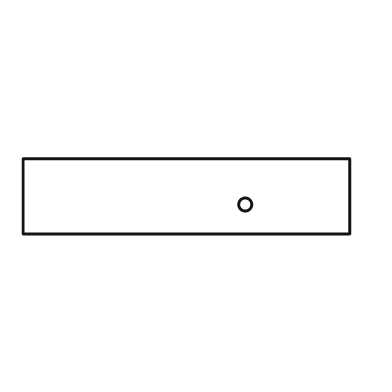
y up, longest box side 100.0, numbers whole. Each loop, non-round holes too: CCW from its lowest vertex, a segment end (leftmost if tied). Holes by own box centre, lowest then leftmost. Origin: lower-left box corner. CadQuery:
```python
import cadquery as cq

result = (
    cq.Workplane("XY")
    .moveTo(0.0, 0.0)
    .lineTo(100.0, 0.0)
    .lineTo(100.0, 23.0)
    .lineTo(0.0, 23.0)
    .close()
    .moveTo(68.0, 9.0)
    .circle(2.0)
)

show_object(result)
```